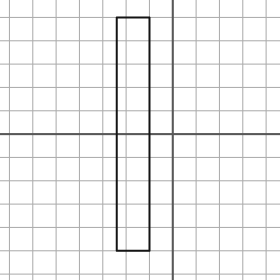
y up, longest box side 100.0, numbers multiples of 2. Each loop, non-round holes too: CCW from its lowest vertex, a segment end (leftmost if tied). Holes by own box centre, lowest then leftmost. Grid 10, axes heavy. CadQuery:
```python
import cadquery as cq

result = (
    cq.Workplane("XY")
    .moveTo(-24.0, -50.0)
    .lineTo(-10.0, -50.0)
    .lineTo(-10.0, 50.0)
    .lineTo(-24.0, 50.0)
    .close()
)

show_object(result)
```